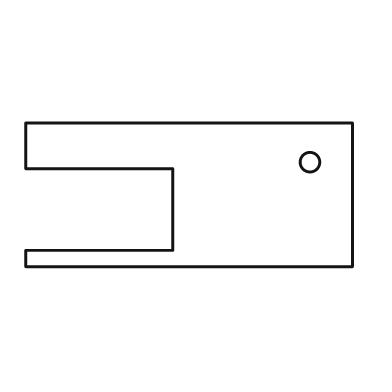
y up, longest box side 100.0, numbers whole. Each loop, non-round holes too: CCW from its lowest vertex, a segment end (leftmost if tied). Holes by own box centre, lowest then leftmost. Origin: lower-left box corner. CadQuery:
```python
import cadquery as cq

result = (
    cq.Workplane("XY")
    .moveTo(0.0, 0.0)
    .lineTo(100.0, 0.0)
    .lineTo(100.0, 44.0)
    .lineTo(0.0, 44.0)
    .lineTo(0.0, 30.0)
    .lineTo(45.0, 30.0)
    .lineTo(45.0, 5.0)
    .lineTo(0.0, 5.0)
    .close()
    .moveTo(87.0, 32.0)
    .circle(3.0)
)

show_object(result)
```